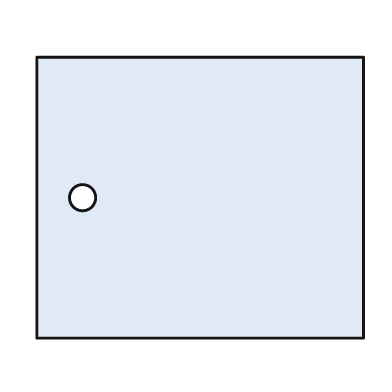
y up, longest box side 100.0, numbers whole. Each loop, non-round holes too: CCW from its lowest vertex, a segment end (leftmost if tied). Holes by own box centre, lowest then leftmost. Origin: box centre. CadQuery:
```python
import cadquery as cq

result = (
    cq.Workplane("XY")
    .moveTo(-50.0, -43.0)
    .lineTo(50.0, -43.0)
    .lineTo(50.0, 43.0)
    .lineTo(-50.0, 43.0)
    .close()
    .moveTo(-36.0, 0.0)
    .circle(4.0)
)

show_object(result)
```